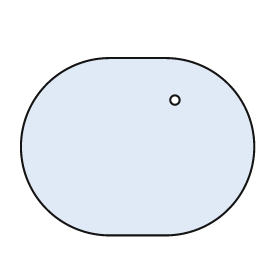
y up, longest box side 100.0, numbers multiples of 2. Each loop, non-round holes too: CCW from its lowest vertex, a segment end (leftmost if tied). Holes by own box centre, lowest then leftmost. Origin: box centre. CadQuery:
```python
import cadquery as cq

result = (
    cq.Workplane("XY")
    .moveTo(-12.0, -38.0)
    .lineTo(12.0, -38.0)
    .threePointArc((50.0, 0.0), (12.0, 38.0))
    .lineTo(-12.0, 38.0)
    .threePointArc((-50.0, 0.0), (-12.0, -38.0))
    .close()
    .moveTo(16.0, 20.0)
    .circle(2.0)
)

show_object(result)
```